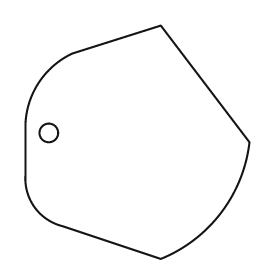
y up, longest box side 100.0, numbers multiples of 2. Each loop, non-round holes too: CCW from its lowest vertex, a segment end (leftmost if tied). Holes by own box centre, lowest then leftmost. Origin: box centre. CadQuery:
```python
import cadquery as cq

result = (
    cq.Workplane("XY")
    .moveTo(10.0, -50.0)
    .threePointArc((36.0, -30.0), (48.0, 0.0))
    .lineTo(10.0, 50.0)
    .lineTo(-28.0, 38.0)
    .threePointArc((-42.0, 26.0), (-48.0, 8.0))
    .lineTo(-48.0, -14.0)
    .threePointArc((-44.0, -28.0), (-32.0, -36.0))
    .close()
    .moveTo(-38.0, 4.0)
    .circle(4.0)
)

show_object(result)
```